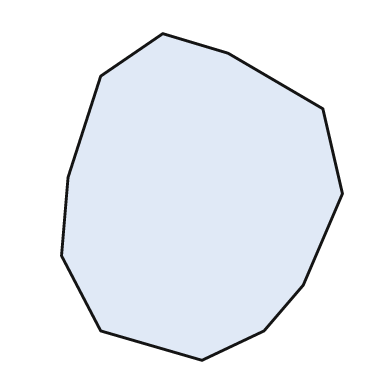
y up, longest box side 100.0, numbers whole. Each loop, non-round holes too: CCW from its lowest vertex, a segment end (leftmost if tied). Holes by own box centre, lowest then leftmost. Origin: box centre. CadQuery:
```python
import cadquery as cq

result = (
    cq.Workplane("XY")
    .moveTo(0.0, -50.0)
    .lineTo(19.0, -41.0)
    .lineTo(31.0, -27.0)
    .lineTo(43.0, 1.0)
    .lineTo(37.0, 27.0)
    .lineTo(8.0, 44.0)
    .lineTo(-12.0, 50.0)
    .lineTo(-31.0, 37.0)
    .lineTo(-41.0, 6.0)
    .lineTo(-43.0, -18.0)
    .lineTo(-31.0, -41.0)
    .close()
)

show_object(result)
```